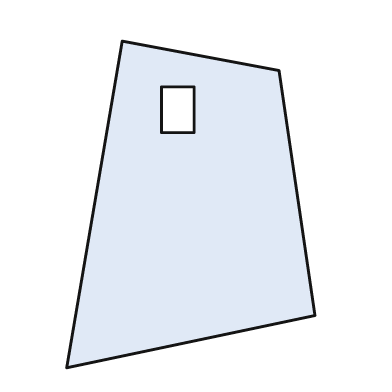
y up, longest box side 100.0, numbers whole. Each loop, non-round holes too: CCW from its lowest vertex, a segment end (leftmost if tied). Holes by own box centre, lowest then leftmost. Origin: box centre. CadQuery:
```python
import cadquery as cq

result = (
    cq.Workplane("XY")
    .moveTo(-38.0, -50.0)
    .lineTo(38.0, -34.0)
    .lineTo(27.0, 41.0)
    .lineTo(-21.0, 50.0)
    .close()
    .moveTo(-9.0, 22.0)
    .lineTo(1.0, 22.0)
    .lineTo(1.0, 36.0)
    .lineTo(-9.0, 36.0)
    .close()
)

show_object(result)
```